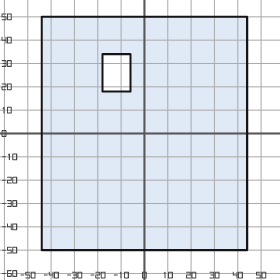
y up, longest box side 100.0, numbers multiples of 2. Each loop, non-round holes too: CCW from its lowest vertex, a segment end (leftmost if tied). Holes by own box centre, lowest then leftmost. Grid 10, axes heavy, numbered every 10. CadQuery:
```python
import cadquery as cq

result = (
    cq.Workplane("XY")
    .moveTo(-44.0, -50.0)
    .lineTo(44.0, -50.0)
    .lineTo(44.0, 50.0)
    .lineTo(-44.0, 50.0)
    .close()
    .moveTo(-18.0, 18.0)
    .lineTo(-6.0, 18.0)
    .lineTo(-6.0, 34.0)
    .lineTo(-18.0, 34.0)
    .close()
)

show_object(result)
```